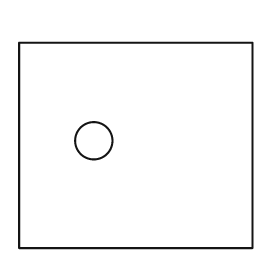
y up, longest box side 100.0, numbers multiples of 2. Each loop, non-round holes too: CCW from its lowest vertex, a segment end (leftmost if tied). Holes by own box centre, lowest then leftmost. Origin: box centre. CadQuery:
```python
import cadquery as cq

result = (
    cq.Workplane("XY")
    .moveTo(-50.0, -44.0)
    .lineTo(50.0, -44.0)
    .lineTo(50.0, 44.0)
    .lineTo(-50.0, 44.0)
    .close()
    .moveTo(-18.0, 2.0)
    .circle(8.0)
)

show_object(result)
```